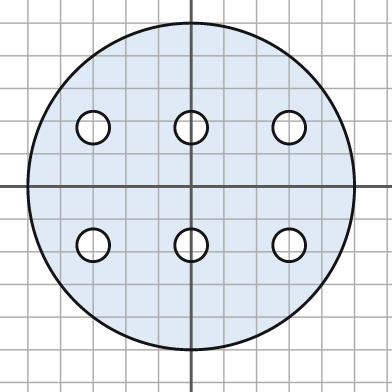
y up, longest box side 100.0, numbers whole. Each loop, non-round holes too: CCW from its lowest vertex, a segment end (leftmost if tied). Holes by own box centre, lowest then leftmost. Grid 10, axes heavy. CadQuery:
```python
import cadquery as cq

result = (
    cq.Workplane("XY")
    .moveTo(0.0, 0.0)
    .circle(50.0)
    .moveTo(-30.0, -18.0)
    .circle(5.0)
    .moveTo(0.0, -18.0)
    .circle(5.0)
    .moveTo(30.0, -18.0)
    .circle(5.0)
    .moveTo(-30.0, 18.0)
    .circle(5.0)
    .moveTo(0.0, 18.0)
    .circle(5.0)
    .moveTo(30.0, 18.0)
    .circle(5.0)
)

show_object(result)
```